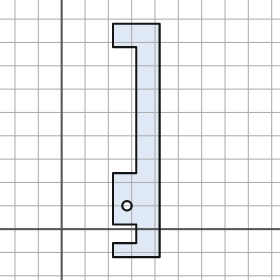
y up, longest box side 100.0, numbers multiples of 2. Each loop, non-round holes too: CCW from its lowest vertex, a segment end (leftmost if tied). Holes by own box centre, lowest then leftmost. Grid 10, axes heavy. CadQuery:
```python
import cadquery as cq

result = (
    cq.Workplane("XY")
    .moveTo(22.0, -12.0)
    .lineTo(42.0, -12.0)
    .lineTo(42.0, 88.0)
    .lineTo(22.0, 88.0)
    .lineTo(22.0, 78.0)
    .lineTo(32.0, 78.0)
    .lineTo(32.0, 24.0)
    .lineTo(22.0, 24.0)
    .lineTo(22.0, 2.0)
    .lineTo(32.0, 2.0)
    .lineTo(32.0, -6.0)
    .lineTo(22.0, -6.0)
    .close()
    .moveTo(28.0, 10.0)
    .circle(2.0)
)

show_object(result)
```